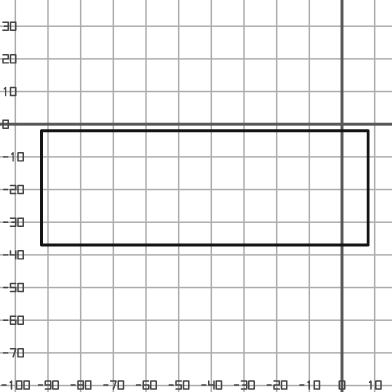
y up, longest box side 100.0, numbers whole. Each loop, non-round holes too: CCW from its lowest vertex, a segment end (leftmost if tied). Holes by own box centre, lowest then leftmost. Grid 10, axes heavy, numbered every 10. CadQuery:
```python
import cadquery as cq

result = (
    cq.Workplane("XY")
    .moveTo(-92.0, -37.0)
    .lineTo(8.0, -37.0)
    .lineTo(8.0, -2.0)
    .lineTo(-92.0, -2.0)
    .close()
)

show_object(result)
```